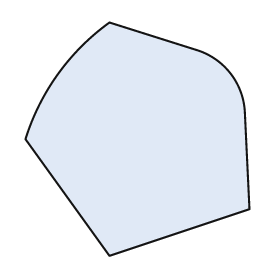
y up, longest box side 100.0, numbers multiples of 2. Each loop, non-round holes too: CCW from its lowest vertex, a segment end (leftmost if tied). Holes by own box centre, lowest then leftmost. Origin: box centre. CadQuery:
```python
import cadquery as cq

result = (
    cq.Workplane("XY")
    .moveTo(-12.0, -50.0)
    .lineTo(48.0, -30.0)
    .lineTo(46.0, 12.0)
    .threePointArc((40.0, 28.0), (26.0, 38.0))
    .lineTo(-12.0, 50.0)
    .threePointArc((-34.0, 28.0), (-48.0, 0.0))
    .close()
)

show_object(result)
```